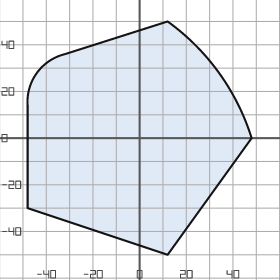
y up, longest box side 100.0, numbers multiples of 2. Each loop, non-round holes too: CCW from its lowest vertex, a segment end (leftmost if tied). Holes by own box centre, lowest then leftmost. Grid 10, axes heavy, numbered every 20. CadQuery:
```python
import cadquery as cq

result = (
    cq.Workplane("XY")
    .moveTo(12.0, -50.0)
    .lineTo(48.0, 0.0)
    .threePointArc((34.0, 28.0), (12.0, 50.0))
    .lineTo(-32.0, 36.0)
    .threePointArc((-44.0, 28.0), (-48.0, 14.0))
    .lineTo(-48.0, -30.0)
    .close()
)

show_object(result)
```